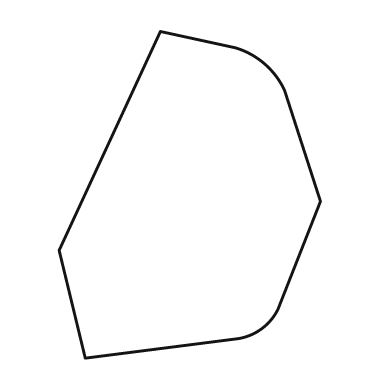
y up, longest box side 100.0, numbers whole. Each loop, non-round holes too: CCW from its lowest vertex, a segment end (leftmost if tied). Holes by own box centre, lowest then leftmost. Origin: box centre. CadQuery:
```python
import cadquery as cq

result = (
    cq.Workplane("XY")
    .moveTo(-32.0, -50.0)
    .lineTo(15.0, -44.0)
    .threePointArc((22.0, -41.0), (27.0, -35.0))
    .lineTo(40.0, -2.0)
    .lineTo(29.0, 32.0)
    .threePointArc((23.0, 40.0), (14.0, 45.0))
    .lineTo(-9.0, 50.0)
    .lineTo(-40.0, -17.0)
    .close()
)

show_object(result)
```